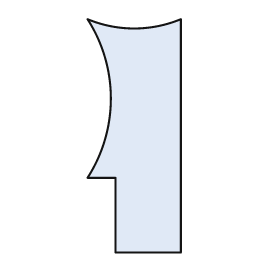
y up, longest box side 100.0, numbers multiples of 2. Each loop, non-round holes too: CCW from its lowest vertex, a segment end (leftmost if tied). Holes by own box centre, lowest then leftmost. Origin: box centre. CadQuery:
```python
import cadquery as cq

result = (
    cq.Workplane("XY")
    .moveTo(-8.0, -50.0)
    .lineTo(20.0, -50.0)
    .lineTo(20.0, 50.0)
    .threePointArc((0.0, 46.0), (-20.0, 50.0))
    .threePointArc((-10.0, 16.0), (-20.0, -18.0))
    .lineTo(-8.0, -18.0)
    .close()
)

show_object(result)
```